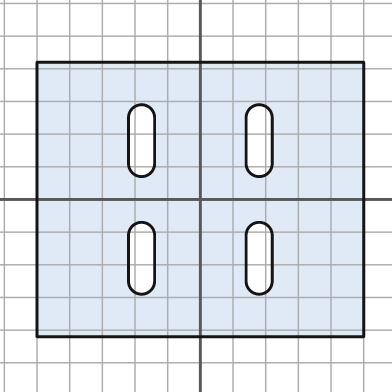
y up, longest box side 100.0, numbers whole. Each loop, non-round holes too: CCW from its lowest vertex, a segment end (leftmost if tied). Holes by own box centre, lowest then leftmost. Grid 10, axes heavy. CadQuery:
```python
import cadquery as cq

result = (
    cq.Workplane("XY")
    .moveTo(-50.0, -42.0)
    .lineTo(50.0, -42.0)
    .lineTo(50.0, 42.0)
    .lineTo(-50.0, 42.0)
    .close()
    .moveTo(-22.0, -25.0)
    .threePointArc((-18.0, -29.0), (-14.0, -25.0))
    .lineTo(-14.0, -11.0)
    .threePointArc((-18.0, -7.0), (-22.0, -11.0))
    .close()
    .moveTo(14.0, -25.0)
    .threePointArc((18.0, -29.0), (22.0, -25.0))
    .lineTo(22.0, -11.0)
    .threePointArc((18.0, -7.0), (14.0, -11.0))
    .close()
    .moveTo(-22.0, 11.0)
    .threePointArc((-18.0, 7.0), (-14.0, 11.0))
    .lineTo(-14.0, 25.0)
    .threePointArc((-18.0, 29.0), (-22.0, 25.0))
    .close()
    .moveTo(14.0, 11.0)
    .threePointArc((18.0, 7.0), (22.0, 11.0))
    .lineTo(22.0, 25.0)
    .threePointArc((18.0, 29.0), (14.0, 25.0))
    .close()
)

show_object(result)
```